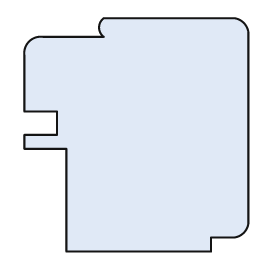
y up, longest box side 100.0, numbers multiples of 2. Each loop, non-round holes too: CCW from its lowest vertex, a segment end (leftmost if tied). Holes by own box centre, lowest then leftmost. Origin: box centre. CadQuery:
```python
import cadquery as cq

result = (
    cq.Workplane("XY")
    .moveTo(-30.0, -50.0)
    .lineTo(32.0, -50.0)
    .lineTo(32.0, -44.0)
    .lineTo(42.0, -44.0)
    .threePointArc((46.0, -42.0), (48.0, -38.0))
    .lineTo(48.0, 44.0)
    .threePointArc((46.0, 48.0), (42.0, 50.0))
    .lineTo(-14.0, 50.0)
    .threePointArc((-16.0, 46.0), (-14.0, 42.0))
    .lineTo(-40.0, 42.0)
    .threePointArc((-46.0, 40.0), (-48.0, 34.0))
    .lineTo(-48.0, 10.0)
    .lineTo(-34.0, 10.0)
    .lineTo(-34.0, 0.0)
    .lineTo(-48.0, 0.0)
    .lineTo(-48.0, -6.0)
    .lineTo(-30.0, -6.0)
    .close()
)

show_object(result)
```